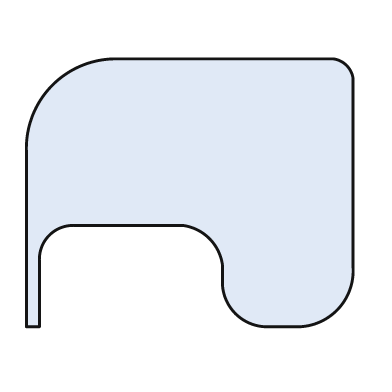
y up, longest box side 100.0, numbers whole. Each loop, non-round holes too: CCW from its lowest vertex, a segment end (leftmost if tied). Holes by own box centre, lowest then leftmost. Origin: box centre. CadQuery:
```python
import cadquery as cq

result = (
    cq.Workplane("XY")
    .moveTo(-50.0, -41.0)
    .lineTo(-46.0, -41.0)
    .lineTo(-46.0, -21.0)
    .threePointArc((-43.0, -13.0), (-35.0, -10.0))
    .lineTo(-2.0, -10.0)
    .threePointArc((6.0, -14.0), (10.0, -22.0))
    .lineTo(10.0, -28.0)
    .threePointArc((14.0, -37.0), (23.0, -41.0))
    .lineTo(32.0, -41.0)
    .threePointArc((45.0, -36.0), (50.0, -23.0))
    .lineTo(50.0, 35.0)
    .threePointArc((48.0, 39.0), (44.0, 41.0))
    .lineTo(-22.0, 41.0)
    .threePointArc((-42.0, 33.0), (-50.0, 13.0))
    .close()
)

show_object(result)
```